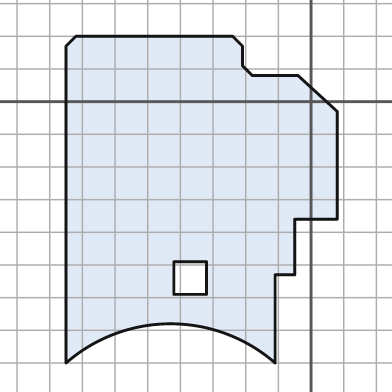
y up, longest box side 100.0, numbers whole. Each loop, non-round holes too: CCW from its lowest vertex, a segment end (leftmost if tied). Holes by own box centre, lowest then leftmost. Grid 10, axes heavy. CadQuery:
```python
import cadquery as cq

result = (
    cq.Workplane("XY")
    .moveTo(-75.0, -80.0)
    .threePointArc((-43.0, -68.0), (-11.0, -80.0))
    .lineTo(-11.0, -53.0)
    .lineTo(-5.0, -53.0)
    .lineTo(-5.0, -36.0)
    .lineTo(8.0, -36.0)
    .lineTo(8.0, -3.0)
    .lineTo(-4.0, 8.0)
    .lineTo(-18.0, 8.0)
    .lineTo(-21.0, 11.0)
    .lineTo(-21.0, 17.0)
    .lineTo(-24.0, 20.0)
    .lineTo(-72.0, 20.0)
    .lineTo(-75.0, 17.0)
    .close()
    .moveTo(-42.0, -59.0)
    .lineTo(-32.0, -59.0)
    .lineTo(-32.0, -49.0)
    .lineTo(-42.0, -49.0)
    .close()
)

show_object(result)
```